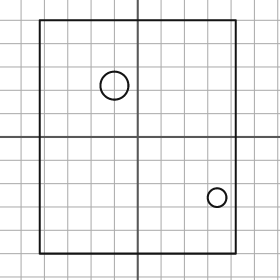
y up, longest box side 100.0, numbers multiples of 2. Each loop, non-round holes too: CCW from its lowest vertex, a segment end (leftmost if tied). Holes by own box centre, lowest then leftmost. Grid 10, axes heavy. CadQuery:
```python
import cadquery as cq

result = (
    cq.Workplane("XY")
    .moveTo(-42.0, -50.0)
    .lineTo(42.0, -50.0)
    .lineTo(42.0, 50.0)
    .lineTo(-42.0, 50.0)
    .close()
    .moveTo(34.0, -26.0)
    .circle(4.0)
    .moveTo(-10.0, 22.0)
    .circle(6.0)
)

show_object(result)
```